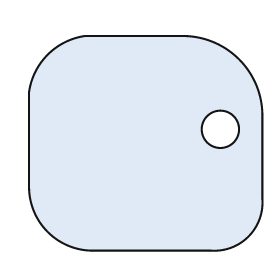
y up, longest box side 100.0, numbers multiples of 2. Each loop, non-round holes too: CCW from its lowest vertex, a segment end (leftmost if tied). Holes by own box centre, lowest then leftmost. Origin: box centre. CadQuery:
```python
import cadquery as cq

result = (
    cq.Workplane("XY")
    .moveTo(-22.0, -46.0)
    .lineTo(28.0, -46.0)
    .threePointArc((44.0, -40.0), (50.0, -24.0))
    .lineTo(50.0, 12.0)
    .threePointArc((40.0, 36.0), (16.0, 46.0))
    .lineTo(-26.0, 46.0)
    .threePointArc((-42.0, 38.0), (-50.0, 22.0))
    .lineTo(-50.0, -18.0)
    .threePointArc((-42.0, -38.0), (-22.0, -46.0))
    .close()
    .moveTo(32.0, 6.0)
    .circle(8.0)
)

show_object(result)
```